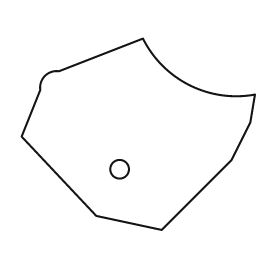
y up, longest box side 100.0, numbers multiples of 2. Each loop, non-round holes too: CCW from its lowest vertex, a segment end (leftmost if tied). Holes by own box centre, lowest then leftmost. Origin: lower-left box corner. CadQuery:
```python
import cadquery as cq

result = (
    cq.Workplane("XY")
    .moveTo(60.0, 0.0)
    .lineTo(90.0, 30.0)
    .lineTo(98.0, 46.0)
    .lineTo(100.0, 58.0)
    .threePointArc((72.0, 62.0), (52.0, 82.0))
    .lineTo(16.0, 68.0)
    .threePointArc((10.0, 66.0), (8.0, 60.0))
    .lineTo(0.0, 40.0)
    .lineTo(32.0, 6.0)
    .close()
    .moveTo(42.0, 26.0)
    .circle(4.0)
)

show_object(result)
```